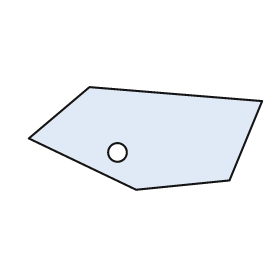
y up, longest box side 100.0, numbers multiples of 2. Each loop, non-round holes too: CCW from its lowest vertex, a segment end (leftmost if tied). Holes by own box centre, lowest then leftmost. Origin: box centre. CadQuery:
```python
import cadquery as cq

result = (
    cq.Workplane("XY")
    .moveTo(-4.0, -22.0)
    .lineTo(36.0, -18.0)
    .lineTo(50.0, 16.0)
    .lineTo(-24.0, 22.0)
    .lineTo(-50.0, 0.0)
    .close()
    .moveTo(-12.0, -6.0)
    .circle(4.0)
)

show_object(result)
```